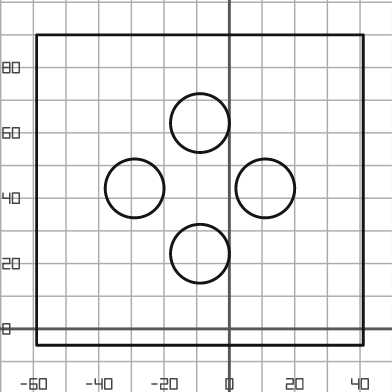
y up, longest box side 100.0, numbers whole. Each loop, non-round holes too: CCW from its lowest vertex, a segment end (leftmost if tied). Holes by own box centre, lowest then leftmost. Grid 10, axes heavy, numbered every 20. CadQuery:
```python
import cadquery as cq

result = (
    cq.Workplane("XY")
    .moveTo(-59.0, -5.0)
    .lineTo(41.0, -5.0)
    .lineTo(41.0, 90.0)
    .lineTo(-59.0, 90.0)
    .close()
    .moveTo(-9.0, 23.0)
    .circle(9.0)
    .moveTo(-29.0, 43.0)
    .circle(9.0)
    .moveTo(11.0, 43.0)
    .circle(9.0)
    .moveTo(-9.0, 63.0)
    .circle(9.0)
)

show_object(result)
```